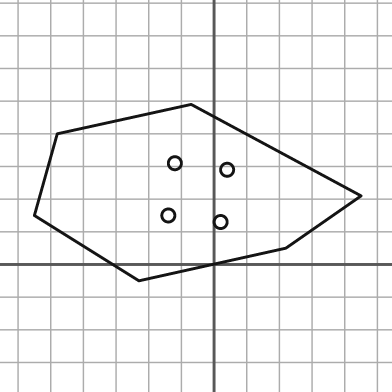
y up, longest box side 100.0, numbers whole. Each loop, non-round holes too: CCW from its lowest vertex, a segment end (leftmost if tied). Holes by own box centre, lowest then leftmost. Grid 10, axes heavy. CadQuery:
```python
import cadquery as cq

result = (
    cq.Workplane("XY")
    .moveTo(-23.0, -5.0)
    .lineTo(22.0, 5.0)
    .lineTo(45.0, 21.0)
    .lineTo(-7.0, 49.0)
    .lineTo(-48.0, 40.0)
    .lineTo(-55.0, 15.0)
    .close()
    .moveTo(2.0, 13.0)
    .circle(2.0)
    .moveTo(-14.0, 15.0)
    .circle(2.0)
    .moveTo(4.0, 29.0)
    .circle(2.0)
    .moveTo(-12.0, 31.0)
    .circle(2.0)
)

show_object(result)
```